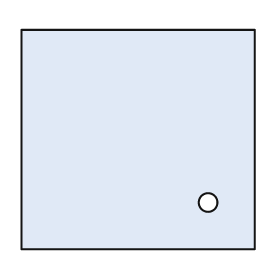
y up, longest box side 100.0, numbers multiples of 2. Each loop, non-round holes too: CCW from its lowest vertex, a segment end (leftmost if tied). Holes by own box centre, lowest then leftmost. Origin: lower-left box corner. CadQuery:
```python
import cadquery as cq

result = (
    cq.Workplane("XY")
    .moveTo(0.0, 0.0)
    .lineTo(100.0, 0.0)
    .lineTo(100.0, 94.0)
    .lineTo(0.0, 94.0)
    .close()
    .moveTo(80.0, 20.0)
    .circle(4.0)
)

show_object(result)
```